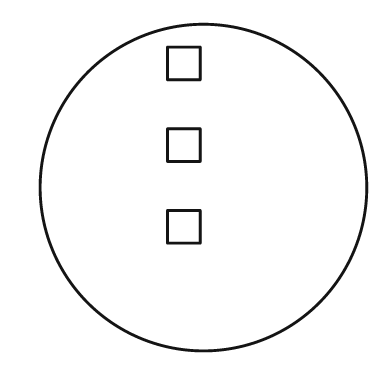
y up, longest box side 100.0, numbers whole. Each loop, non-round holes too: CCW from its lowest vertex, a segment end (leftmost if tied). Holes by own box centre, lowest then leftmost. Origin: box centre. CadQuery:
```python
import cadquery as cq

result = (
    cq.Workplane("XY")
    .moveTo(0.0, 0.0)
    .circle(50.0)
    .moveTo(-11.0, -17.0)
    .lineTo(-1.0, -17.0)
    .lineTo(-1.0, -7.0)
    .lineTo(-11.0, -7.0)
    .close()
    .moveTo(-11.0, 8.0)
    .lineTo(-1.0, 8.0)
    .lineTo(-1.0, 18.0)
    .lineTo(-11.0, 18.0)
    .close()
    .moveTo(-11.0, 33.0)
    .lineTo(-1.0, 33.0)
    .lineTo(-1.0, 43.0)
    .lineTo(-11.0, 43.0)
    .close()
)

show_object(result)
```